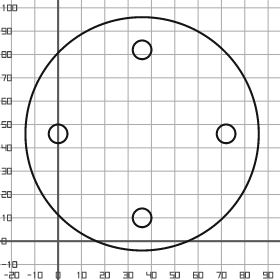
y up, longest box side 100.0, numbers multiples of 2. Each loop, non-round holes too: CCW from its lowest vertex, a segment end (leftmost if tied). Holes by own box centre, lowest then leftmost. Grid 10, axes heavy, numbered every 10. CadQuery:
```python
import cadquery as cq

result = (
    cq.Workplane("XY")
    .moveTo(36.0, 46.0)
    .circle(50.0)
    .moveTo(36.0, 10.0)
    .circle(4.0)
    .moveTo(0.0, 46.0)
    .circle(4.0)
    .moveTo(72.0, 46.0)
    .circle(4.0)
    .moveTo(36.0, 82.0)
    .circle(4.0)
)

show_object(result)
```